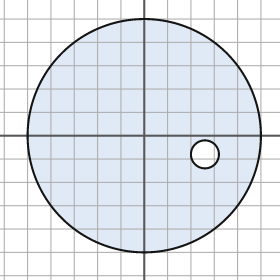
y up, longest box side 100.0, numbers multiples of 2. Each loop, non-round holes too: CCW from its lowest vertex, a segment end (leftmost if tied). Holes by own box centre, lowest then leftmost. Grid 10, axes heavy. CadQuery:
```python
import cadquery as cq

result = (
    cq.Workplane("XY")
    .moveTo(0.0, 0.0)
    .circle(50.0)
    .moveTo(26.0, -8.0)
    .circle(6.0)
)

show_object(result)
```